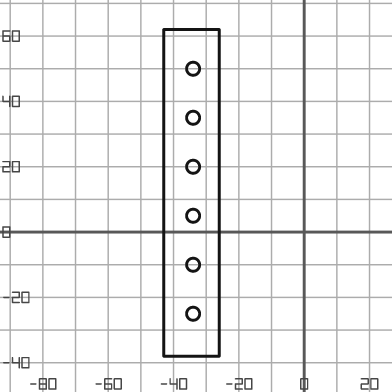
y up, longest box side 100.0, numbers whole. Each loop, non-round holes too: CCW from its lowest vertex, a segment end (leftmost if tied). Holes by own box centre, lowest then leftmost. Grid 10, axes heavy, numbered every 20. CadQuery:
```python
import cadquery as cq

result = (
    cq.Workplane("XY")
    .moveTo(-43.0, -38.0)
    .lineTo(-26.0, -38.0)
    .lineTo(-26.0, 62.0)
    .lineTo(-43.0, 62.0)
    .close()
    .moveTo(-34.0, -25.0)
    .circle(2.0)
    .moveTo(-34.0, -10.0)
    .circle(2.0)
    .moveTo(-34.0, 5.0)
    .circle(2.0)
    .moveTo(-34.0, 20.0)
    .circle(2.0)
    .moveTo(-34.0, 35.0)
    .circle(2.0)
    .moveTo(-34.0, 50.0)
    .circle(2.0)
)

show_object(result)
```